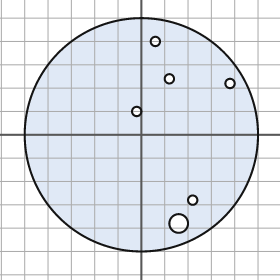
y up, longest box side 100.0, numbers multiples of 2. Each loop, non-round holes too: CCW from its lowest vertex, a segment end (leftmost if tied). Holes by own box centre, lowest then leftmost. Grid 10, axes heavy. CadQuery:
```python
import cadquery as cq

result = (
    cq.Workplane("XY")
    .moveTo(0.0, 0.0)
    .circle(50.0)
    .moveTo(16.0, -38.0)
    .circle(4.0)
    .moveTo(22.0, -28.0)
    .circle(2.0)
    .moveTo(-2.0, 10.0)
    .circle(2.0)
    .moveTo(38.0, 22.0)
    .circle(2.0)
    .moveTo(12.0, 24.0)
    .circle(2.0)
    .moveTo(6.0, 40.0)
    .circle(2.0)
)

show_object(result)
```